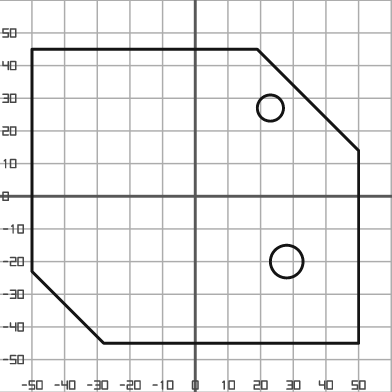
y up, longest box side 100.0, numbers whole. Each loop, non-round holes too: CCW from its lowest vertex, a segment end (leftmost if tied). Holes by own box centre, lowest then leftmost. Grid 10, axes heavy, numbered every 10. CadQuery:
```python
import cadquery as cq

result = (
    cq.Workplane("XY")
    .moveTo(-28.0, -45.0)
    .lineTo(50.0, -45.0)
    .lineTo(50.0, 14.0)
    .lineTo(19.0, 45.0)
    .lineTo(-50.0, 45.0)
    .lineTo(-50.0, -23.0)
    .close()
    .moveTo(28.0, -20.0)
    .circle(5.0)
    .moveTo(23.0, 27.0)
    .circle(4.0)
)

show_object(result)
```